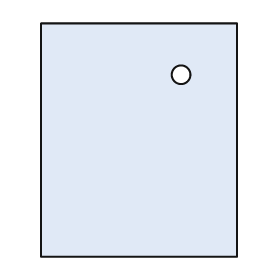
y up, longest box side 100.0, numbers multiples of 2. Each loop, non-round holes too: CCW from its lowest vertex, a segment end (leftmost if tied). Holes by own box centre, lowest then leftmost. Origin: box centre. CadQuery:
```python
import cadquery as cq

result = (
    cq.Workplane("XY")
    .moveTo(-42.0, -50.0)
    .lineTo(42.0, -50.0)
    .lineTo(42.0, 50.0)
    .lineTo(-42.0, 50.0)
    .close()
    .moveTo(18.0, 28.0)
    .circle(4.0)
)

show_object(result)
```